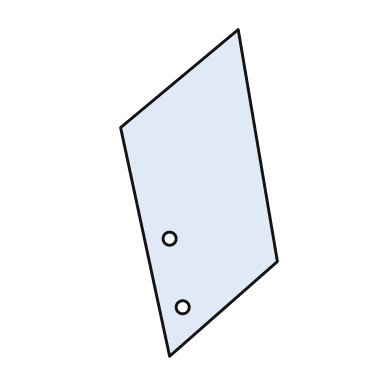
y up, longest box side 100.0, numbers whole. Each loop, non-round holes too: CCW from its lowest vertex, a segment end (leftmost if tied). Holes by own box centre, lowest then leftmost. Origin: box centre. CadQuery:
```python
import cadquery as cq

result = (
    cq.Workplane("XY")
    .moveTo(-9.0, -50.0)
    .lineTo(24.0, -21.0)
    .lineTo(12.0, 50.0)
    .lineTo(-24.0, 20.0)
    .close()
    .moveTo(-5.0, -35.0)
    .circle(2.0)
    .moveTo(-9.0, -14.0)
    .circle(2.0)
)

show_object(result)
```